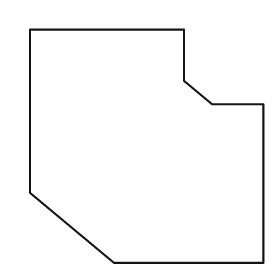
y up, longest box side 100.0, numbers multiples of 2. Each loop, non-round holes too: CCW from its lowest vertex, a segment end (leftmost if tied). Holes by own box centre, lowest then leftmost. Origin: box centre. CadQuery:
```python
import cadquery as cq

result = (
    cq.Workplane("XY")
    .moveTo(-14.0, -50.0)
    .lineTo(50.0, -50.0)
    .lineTo(50.0, 18.0)
    .lineTo(28.0, 18.0)
    .lineTo(16.0, 28.0)
    .lineTo(16.0, 50.0)
    .lineTo(-50.0, 50.0)
    .lineTo(-50.0, -20.0)
    .close()
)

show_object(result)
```